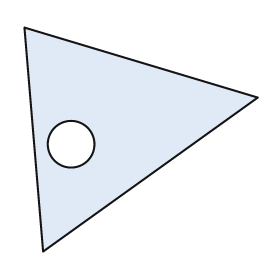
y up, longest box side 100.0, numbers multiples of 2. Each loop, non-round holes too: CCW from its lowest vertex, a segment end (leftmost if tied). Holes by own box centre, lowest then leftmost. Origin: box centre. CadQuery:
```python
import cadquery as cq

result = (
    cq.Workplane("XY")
    .moveTo(-42.0, -48.0)
    .lineTo(50.0, 18.0)
    .lineTo(-50.0, 48.0)
    .close()
    .moveTo(-30.0, -2.0)
    .circle(10.0)
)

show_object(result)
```